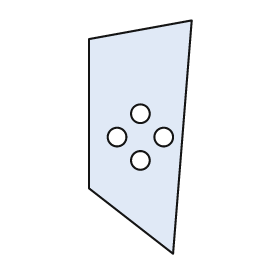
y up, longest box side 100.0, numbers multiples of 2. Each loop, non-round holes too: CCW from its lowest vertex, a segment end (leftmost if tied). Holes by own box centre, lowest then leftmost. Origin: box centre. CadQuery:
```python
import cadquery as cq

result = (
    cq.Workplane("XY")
    .moveTo(14.0, -50.0)
    .lineTo(22.0, 50.0)
    .lineTo(-22.0, 42.0)
    .lineTo(-22.0, -22.0)
    .close()
    .moveTo(0.0, -10.0)
    .circle(4.0)
    .moveTo(-10.0, 0.0)
    .circle(4.0)
    .moveTo(10.0, 0.0)
    .circle(4.0)
    .moveTo(0.0, 10.0)
    .circle(4.0)
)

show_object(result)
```